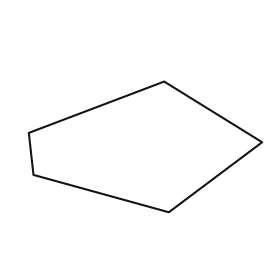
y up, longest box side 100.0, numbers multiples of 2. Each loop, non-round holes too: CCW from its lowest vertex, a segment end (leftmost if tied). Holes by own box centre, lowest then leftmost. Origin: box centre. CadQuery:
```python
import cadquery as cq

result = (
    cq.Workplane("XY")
    .moveTo(10.0, -28.0)
    .lineTo(50.0, 2.0)
    .lineTo(8.0, 28.0)
    .lineTo(-50.0, 6.0)
    .lineTo(-48.0, -12.0)
    .close()
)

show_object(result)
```